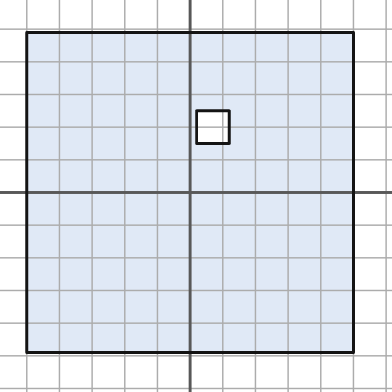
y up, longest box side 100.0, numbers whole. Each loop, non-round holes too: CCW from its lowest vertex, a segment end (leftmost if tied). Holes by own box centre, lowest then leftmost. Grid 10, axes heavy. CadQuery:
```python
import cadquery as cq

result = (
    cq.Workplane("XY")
    .moveTo(-50.0, -49.0)
    .lineTo(50.0, -49.0)
    .lineTo(50.0, 49.0)
    .lineTo(-50.0, 49.0)
    .close()
    .moveTo(2.0, 15.0)
    .lineTo(12.0, 15.0)
    .lineTo(12.0, 25.0)
    .lineTo(2.0, 25.0)
    .close()
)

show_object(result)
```